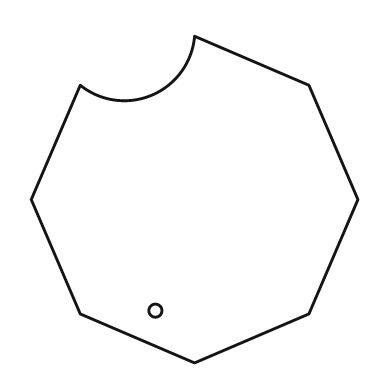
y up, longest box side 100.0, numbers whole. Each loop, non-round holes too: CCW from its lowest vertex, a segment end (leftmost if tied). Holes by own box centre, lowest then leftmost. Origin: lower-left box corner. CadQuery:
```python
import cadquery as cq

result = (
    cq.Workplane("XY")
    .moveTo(50.0, 0.0)
    .lineTo(85.0, 15.0)
    .lineTo(100.0, 50.0)
    .lineTo(85.0, 85.0)
    .lineTo(50.0, 100.0)
    .threePointArc((37.0, 82.0), (15.0, 85.0))
    .lineTo(0.0, 50.0)
    .lineTo(15.0, 15.0)
    .close()
    .moveTo(38.0, 16.0)
    .circle(2.0)
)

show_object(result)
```